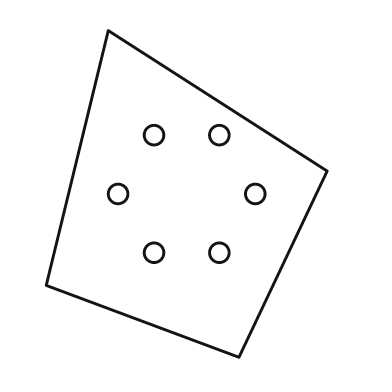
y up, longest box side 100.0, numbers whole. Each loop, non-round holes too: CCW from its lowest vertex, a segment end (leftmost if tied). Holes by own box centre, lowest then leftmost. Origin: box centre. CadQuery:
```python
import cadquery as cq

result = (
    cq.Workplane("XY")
    .moveTo(16.0, -50.0)
    .lineTo(43.0, 7.0)
    .lineTo(-24.0, 50.0)
    .lineTo(-43.0, -28.0)
    .close()
    .moveTo(-10.0, -18.0)
    .circle(3.0)
    .moveTo(10.0, -18.0)
    .circle(3.0)
    .moveTo(-21.0, 0.0)
    .circle(3.0)
    .moveTo(21.0, 0.0)
    .circle(3.0)
    .moveTo(-10.0, 18.0)
    .circle(3.0)
    .moveTo(10.0, 18.0)
    .circle(3.0)
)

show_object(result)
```